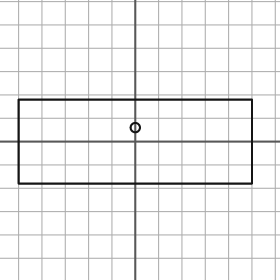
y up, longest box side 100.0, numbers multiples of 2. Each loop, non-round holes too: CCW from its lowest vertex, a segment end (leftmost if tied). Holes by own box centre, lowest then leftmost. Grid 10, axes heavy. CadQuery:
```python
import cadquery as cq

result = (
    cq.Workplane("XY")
    .moveTo(-50.0, -18.0)
    .lineTo(50.0, -18.0)
    .lineTo(50.0, 18.0)
    .lineTo(-50.0, 18.0)
    .close()
    .moveTo(0.0, 6.0)
    .circle(2.0)
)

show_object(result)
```